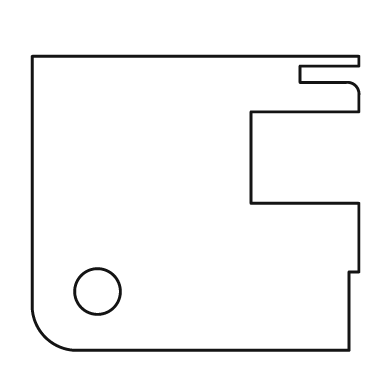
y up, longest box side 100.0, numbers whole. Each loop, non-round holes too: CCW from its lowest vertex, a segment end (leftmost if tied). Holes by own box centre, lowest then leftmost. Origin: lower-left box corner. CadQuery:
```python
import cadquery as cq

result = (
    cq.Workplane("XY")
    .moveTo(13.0, 0.0)
    .lineTo(97.0, 0.0)
    .lineTo(97.0, 24.0)
    .lineTo(100.0, 24.0)
    .lineTo(100.0, 45.0)
    .lineTo(67.0, 45.0)
    .lineTo(67.0, 73.0)
    .lineTo(100.0, 73.0)
    .lineTo(100.0, 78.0)
    .threePointArc((99.0, 81.0), (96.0, 82.0))
    .lineTo(82.0, 82.0)
    .lineTo(82.0, 87.0)
    .lineTo(100.0, 87.0)
    .lineTo(100.0, 90.0)
    .lineTo(0.0, 90.0)
    .lineTo(0.0, 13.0)
    .threePointArc((4.0, 4.0), (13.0, 0.0))
    .close()
    .moveTo(20.0, 18.0)
    .circle(7.0)
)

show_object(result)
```